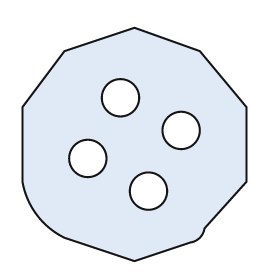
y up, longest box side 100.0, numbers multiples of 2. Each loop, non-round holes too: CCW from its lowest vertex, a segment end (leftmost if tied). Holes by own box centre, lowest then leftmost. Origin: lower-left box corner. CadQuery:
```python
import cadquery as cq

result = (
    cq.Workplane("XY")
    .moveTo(48.0, 0.0)
    .lineTo(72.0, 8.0)
    .threePointArc((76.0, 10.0), (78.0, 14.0))
    .lineTo(96.0, 34.0)
    .lineTo(96.0, 66.0)
    .lineTo(76.0, 90.0)
    .lineTo(48.0, 100.0)
    .lineTo(18.0, 90.0)
    .lineTo(0.0, 66.0)
    .lineTo(0.0, 34.0)
    .threePointArc((6.0, 20.0), (18.0, 10.0))
    .close()
    .moveTo(54.0, 30.0)
    .circle(8.0)
    .moveTo(28.0, 44.0)
    .circle(8.0)
    .moveTo(68.0, 56.0)
    .circle(8.0)
    .moveTo(42.0, 70.0)
    .circle(8.0)
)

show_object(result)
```